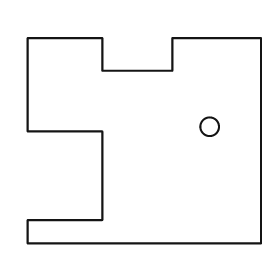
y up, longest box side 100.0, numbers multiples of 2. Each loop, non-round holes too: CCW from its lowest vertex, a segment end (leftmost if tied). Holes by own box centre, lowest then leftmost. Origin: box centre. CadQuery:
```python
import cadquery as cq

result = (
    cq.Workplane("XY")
    .moveTo(-50.0, -44.0)
    .lineTo(50.0, -44.0)
    .lineTo(50.0, 44.0)
    .lineTo(12.0, 44.0)
    .lineTo(12.0, 30.0)
    .lineTo(-18.0, 30.0)
    .lineTo(-18.0, 44.0)
    .lineTo(-50.0, 44.0)
    .lineTo(-50.0, 4.0)
    .lineTo(-18.0, 4.0)
    .lineTo(-18.0, -34.0)
    .lineTo(-50.0, -34.0)
    .close()
    .moveTo(28.0, 6.0)
    .circle(4.0)
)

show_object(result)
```